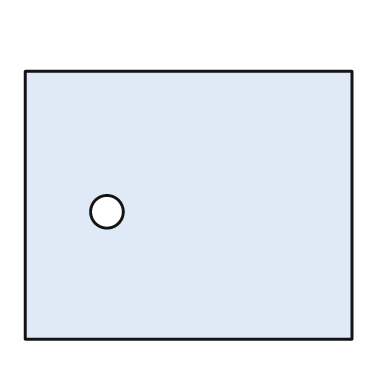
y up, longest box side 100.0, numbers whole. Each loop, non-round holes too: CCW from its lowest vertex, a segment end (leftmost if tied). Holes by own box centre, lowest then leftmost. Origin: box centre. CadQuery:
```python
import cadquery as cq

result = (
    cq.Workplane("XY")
    .moveTo(-50.0, -41.0)
    .lineTo(50.0, -41.0)
    .lineTo(50.0, 41.0)
    .lineTo(-50.0, 41.0)
    .close()
    .moveTo(-25.0, -2.0)
    .circle(5.0)
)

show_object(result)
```